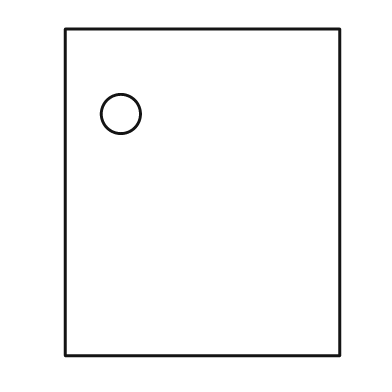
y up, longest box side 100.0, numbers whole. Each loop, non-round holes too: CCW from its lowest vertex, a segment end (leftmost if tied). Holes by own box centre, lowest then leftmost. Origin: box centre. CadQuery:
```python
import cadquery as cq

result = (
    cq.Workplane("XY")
    .moveTo(-42.0, -50.0)
    .lineTo(42.0, -50.0)
    .lineTo(42.0, 50.0)
    .lineTo(-42.0, 50.0)
    .close()
    .moveTo(-25.0, 24.0)
    .circle(6.0)
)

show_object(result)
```